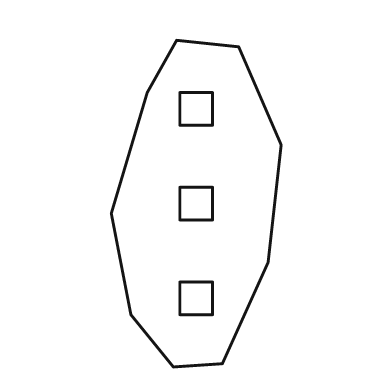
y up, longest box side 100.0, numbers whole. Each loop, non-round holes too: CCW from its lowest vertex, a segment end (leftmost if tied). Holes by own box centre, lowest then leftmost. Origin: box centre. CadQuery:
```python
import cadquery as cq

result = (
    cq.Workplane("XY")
    .moveTo(-7.0, -50.0)
    .lineTo(8.0, -49.0)
    .lineTo(22.0, -18.0)
    .lineTo(26.0, 18.0)
    .lineTo(13.0, 48.0)
    .lineTo(-6.0, 50.0)
    .lineTo(-15.0, 34.0)
    .lineTo(-26.0, -3.0)
    .lineTo(-20.0, -34.0)
    .close()
    .moveTo(-5.0, -34.0)
    .lineTo(5.0, -34.0)
    .lineTo(5.0, -24.0)
    .lineTo(-5.0, -24.0)
    .close()
    .moveTo(-5.0, -5.0)
    .lineTo(5.0, -5.0)
    .lineTo(5.0, 5.0)
    .lineTo(-5.0, 5.0)
    .close()
    .moveTo(-5.0, 24.0)
    .lineTo(5.0, 24.0)
    .lineTo(5.0, 34.0)
    .lineTo(-5.0, 34.0)
    .close()
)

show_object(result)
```